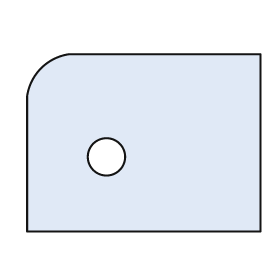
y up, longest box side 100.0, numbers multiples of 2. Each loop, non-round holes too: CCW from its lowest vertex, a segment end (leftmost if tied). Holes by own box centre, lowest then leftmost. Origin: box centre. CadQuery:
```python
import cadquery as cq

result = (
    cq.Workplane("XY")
    .moveTo(-50.0, -38.0)
    .lineTo(50.0, -38.0)
    .lineTo(50.0, 38.0)
    .lineTo(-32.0, 38.0)
    .threePointArc((-44.0, 32.0), (-50.0, 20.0))
    .close()
    .moveTo(-16.0, -6.0)
    .circle(8.0)
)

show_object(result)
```